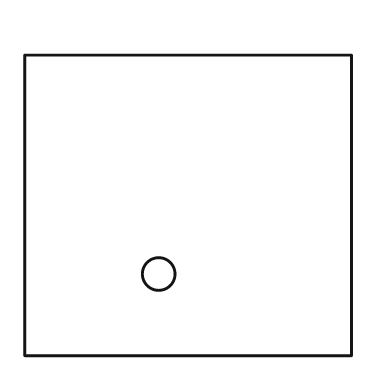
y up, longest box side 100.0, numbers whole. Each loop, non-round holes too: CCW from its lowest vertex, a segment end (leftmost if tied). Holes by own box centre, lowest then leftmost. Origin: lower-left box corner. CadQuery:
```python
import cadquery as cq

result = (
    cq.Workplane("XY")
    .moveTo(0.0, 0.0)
    .lineTo(100.0, 0.0)
    .lineTo(100.0, 92.0)
    .lineTo(0.0, 92.0)
    .close()
    .moveTo(41.0, 25.0)
    .circle(5.0)
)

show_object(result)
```